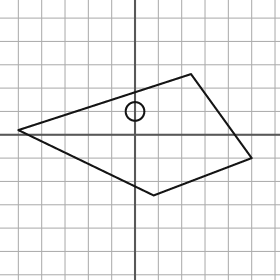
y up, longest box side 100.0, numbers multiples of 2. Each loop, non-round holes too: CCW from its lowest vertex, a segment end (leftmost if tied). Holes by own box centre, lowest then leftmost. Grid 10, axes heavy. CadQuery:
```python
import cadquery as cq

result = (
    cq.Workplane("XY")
    .moveTo(8.0, -26.0)
    .lineTo(50.0, -10.0)
    .lineTo(24.0, 26.0)
    .lineTo(-50.0, 2.0)
    .close()
    .moveTo(0.0, 10.0)
    .circle(4.0)
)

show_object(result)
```